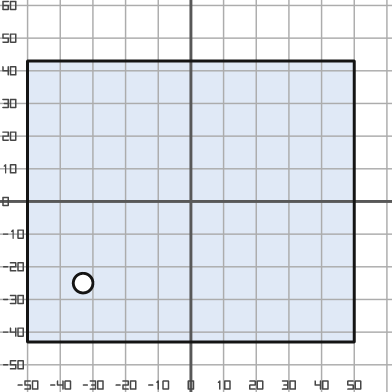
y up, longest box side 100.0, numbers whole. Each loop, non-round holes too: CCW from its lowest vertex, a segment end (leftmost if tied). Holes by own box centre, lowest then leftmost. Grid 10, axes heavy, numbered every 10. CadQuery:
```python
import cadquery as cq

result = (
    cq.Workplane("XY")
    .moveTo(-50.0, -43.0)
    .lineTo(50.0, -43.0)
    .lineTo(50.0, 43.0)
    .lineTo(-50.0, 43.0)
    .close()
    .moveTo(-33.0, -25.0)
    .circle(3.0)
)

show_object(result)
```